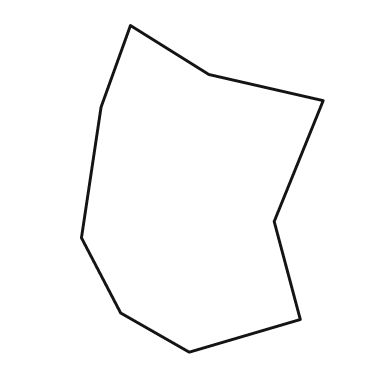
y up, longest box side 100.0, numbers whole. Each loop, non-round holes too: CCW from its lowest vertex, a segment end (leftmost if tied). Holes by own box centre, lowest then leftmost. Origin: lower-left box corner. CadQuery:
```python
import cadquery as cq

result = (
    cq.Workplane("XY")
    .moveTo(33.0, 0.0)
    .lineTo(67.0, 10.0)
    .lineTo(59.0, 40.0)
    .lineTo(74.0, 77.0)
    .lineTo(39.0, 85.0)
    .lineTo(15.0, 100.0)
    .lineTo(6.0, 75.0)
    .lineTo(0.0, 35.0)
    .lineTo(12.0, 12.0)
    .close()
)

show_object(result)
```